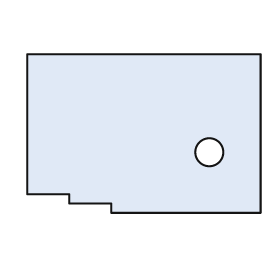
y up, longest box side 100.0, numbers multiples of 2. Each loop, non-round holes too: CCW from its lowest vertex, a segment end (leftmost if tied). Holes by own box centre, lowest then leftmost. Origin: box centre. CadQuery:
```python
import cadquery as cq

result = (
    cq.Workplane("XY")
    .moveTo(-14.0, -34.0)
    .lineTo(50.0, -34.0)
    .lineTo(50.0, 34.0)
    .lineTo(-50.0, 34.0)
    .lineTo(-50.0, -26.0)
    .lineTo(-32.0, -26.0)
    .lineTo(-32.0, -30.0)
    .lineTo(-14.0, -30.0)
    .close()
    .moveTo(28.0, -8.0)
    .circle(6.0)
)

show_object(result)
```